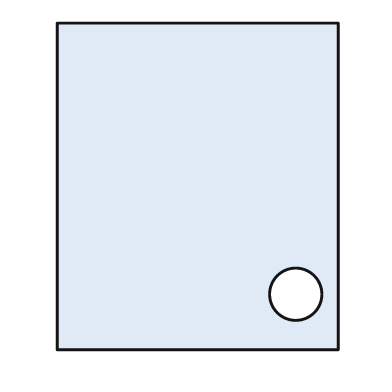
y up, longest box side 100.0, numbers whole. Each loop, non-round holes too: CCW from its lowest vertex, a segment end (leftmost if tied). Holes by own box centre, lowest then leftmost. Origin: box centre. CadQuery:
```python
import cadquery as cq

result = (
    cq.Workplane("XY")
    .moveTo(-43.0, -50.0)
    .lineTo(43.0, -50.0)
    .lineTo(43.0, 50.0)
    .lineTo(-43.0, 50.0)
    .close()
    .moveTo(30.0, -33.0)
    .circle(8.0)
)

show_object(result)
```